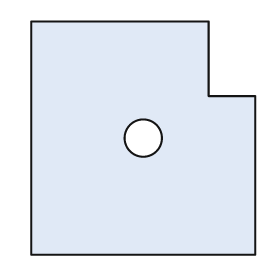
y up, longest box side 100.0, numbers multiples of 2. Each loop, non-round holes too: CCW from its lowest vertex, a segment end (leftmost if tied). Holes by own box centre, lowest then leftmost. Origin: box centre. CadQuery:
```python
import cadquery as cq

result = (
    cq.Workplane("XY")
    .moveTo(-48.0, -50.0)
    .lineTo(48.0, -50.0)
    .lineTo(48.0, 18.0)
    .lineTo(28.0, 18.0)
    .lineTo(28.0, 50.0)
    .lineTo(-48.0, 50.0)
    .close()
    .moveTo(0.0, 0.0)
    .circle(8.0)
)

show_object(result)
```